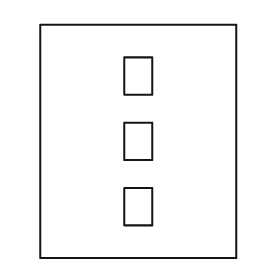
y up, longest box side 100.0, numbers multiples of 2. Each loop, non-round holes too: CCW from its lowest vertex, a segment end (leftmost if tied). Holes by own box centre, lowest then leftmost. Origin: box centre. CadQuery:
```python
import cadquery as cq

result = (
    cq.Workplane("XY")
    .moveTo(-42.0, -50.0)
    .lineTo(42.0, -50.0)
    .lineTo(42.0, 50.0)
    .lineTo(-42.0, 50.0)
    .close()
    .moveTo(-6.0, -36.0)
    .lineTo(6.0, -36.0)
    .lineTo(6.0, -20.0)
    .lineTo(-6.0, -20.0)
    .close()
    .moveTo(-6.0, -8.0)
    .lineTo(6.0, -8.0)
    .lineTo(6.0, 8.0)
    .lineTo(-6.0, 8.0)
    .close()
    .moveTo(-6.0, 20.0)
    .lineTo(6.0, 20.0)
    .lineTo(6.0, 36.0)
    .lineTo(-6.0, 36.0)
    .close()
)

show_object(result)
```